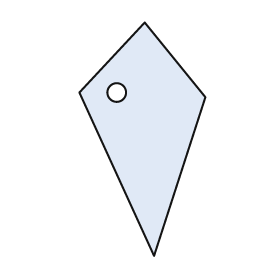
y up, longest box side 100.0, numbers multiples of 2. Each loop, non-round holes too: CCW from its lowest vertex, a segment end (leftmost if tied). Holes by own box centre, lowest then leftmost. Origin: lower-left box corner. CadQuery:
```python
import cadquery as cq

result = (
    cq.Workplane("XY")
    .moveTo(32.0, 0.0)
    .lineTo(54.0, 68.0)
    .lineTo(28.0, 100.0)
    .lineTo(0.0, 70.0)
    .close()
    .moveTo(16.0, 70.0)
    .circle(4.0)
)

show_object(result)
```